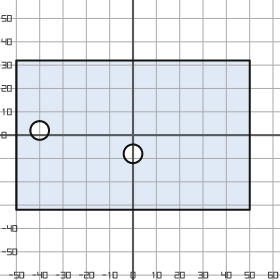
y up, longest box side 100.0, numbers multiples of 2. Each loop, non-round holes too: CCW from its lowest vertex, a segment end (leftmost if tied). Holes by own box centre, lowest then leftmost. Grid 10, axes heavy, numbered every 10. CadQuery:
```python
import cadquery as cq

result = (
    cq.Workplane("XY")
    .moveTo(-50.0, -32.0)
    .lineTo(50.0, -32.0)
    .lineTo(50.0, 32.0)
    .lineTo(-50.0, 32.0)
    .close()
    .moveTo(0.0, -8.0)
    .circle(4.0)
    .moveTo(-40.0, 2.0)
    .circle(4.0)
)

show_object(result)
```